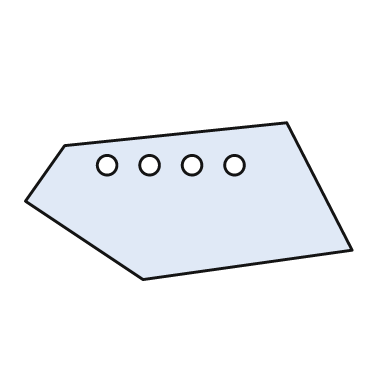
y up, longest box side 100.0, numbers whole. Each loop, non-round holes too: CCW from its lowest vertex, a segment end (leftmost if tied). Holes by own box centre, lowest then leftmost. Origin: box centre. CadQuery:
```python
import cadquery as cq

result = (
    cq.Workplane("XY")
    .moveTo(-14.0, -24.0)
    .lineTo(50.0, -15.0)
    .lineTo(30.0, 24.0)
    .lineTo(-38.0, 17.0)
    .lineTo(-50.0, 0.0)
    .close()
    .moveTo(-25.0, 11.0)
    .circle(3.0)
    .moveTo(-12.0, 11.0)
    .circle(3.0)
    .moveTo(1.0, 11.0)
    .circle(3.0)
    .moveTo(14.0, 11.0)
    .circle(3.0)
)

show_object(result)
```